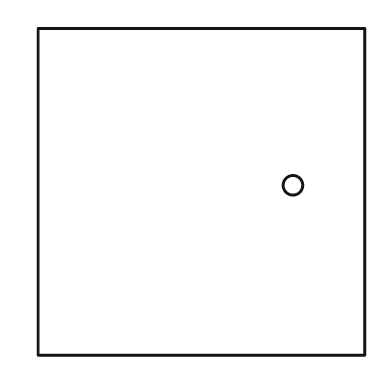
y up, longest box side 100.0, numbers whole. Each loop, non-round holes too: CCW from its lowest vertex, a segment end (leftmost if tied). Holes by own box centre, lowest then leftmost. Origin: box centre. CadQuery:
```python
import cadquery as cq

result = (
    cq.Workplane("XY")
    .moveTo(-50.0, -50.0)
    .lineTo(50.0, -50.0)
    .lineTo(50.0, 50.0)
    .lineTo(-50.0, 50.0)
    .close()
    .moveTo(28.0, 2.0)
    .circle(3.0)
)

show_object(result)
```